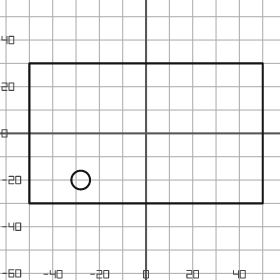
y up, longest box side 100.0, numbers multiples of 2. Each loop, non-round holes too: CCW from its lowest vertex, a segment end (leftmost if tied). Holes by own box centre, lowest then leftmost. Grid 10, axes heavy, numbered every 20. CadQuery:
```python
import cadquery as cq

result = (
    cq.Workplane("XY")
    .moveTo(-50.0, -30.0)
    .lineTo(50.0, -30.0)
    .lineTo(50.0, 30.0)
    .lineTo(-50.0, 30.0)
    .close()
    .moveTo(-28.0, -20.0)
    .circle(4.0)
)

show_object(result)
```